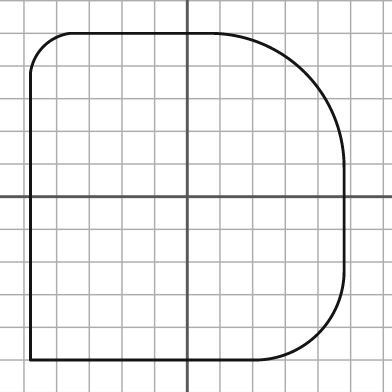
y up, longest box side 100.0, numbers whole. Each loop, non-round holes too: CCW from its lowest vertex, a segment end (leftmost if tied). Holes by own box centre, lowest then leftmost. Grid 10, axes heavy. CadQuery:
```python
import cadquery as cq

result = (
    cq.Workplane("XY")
    .moveTo(-48.0, -50.0)
    .lineTo(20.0, -50.0)
    .threePointArc((40.0, -42.0), (48.0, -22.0))
    .lineTo(48.0, 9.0)
    .threePointArc((36.0, 38.0), (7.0, 50.0))
    .lineTo(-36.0, 50.0)
    .threePointArc((-44.0, 46.0), (-48.0, 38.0))
    .close()
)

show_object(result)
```